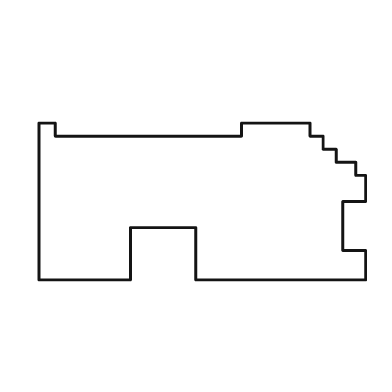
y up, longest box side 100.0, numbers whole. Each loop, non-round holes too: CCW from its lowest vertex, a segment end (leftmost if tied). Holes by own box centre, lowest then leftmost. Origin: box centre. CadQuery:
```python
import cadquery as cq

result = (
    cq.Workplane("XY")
    .moveTo(-50.0, -24.0)
    .lineTo(-22.0, -24.0)
    .lineTo(-22.0, -8.0)
    .lineTo(-2.0, -8.0)
    .lineTo(-2.0, -24.0)
    .lineTo(50.0, -24.0)
    .lineTo(50.0, -15.0)
    .lineTo(43.0, -15.0)
    .lineTo(43.0, 0.0)
    .lineTo(50.0, 0.0)
    .lineTo(50.0, 8.0)
    .lineTo(47.0, 8.0)
    .lineTo(47.0, 12.0)
    .lineTo(41.0, 12.0)
    .lineTo(41.0, 16.0)
    .lineTo(37.0, 16.0)
    .lineTo(37.0, 20.0)
    .lineTo(33.0, 20.0)
    .lineTo(33.0, 24.0)
    .lineTo(12.0, 24.0)
    .lineTo(12.0, 20.0)
    .lineTo(-45.0, 20.0)
    .lineTo(-45.0, 24.0)
    .lineTo(-50.0, 24.0)
    .close()
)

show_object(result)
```